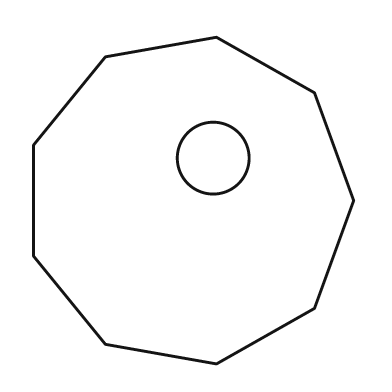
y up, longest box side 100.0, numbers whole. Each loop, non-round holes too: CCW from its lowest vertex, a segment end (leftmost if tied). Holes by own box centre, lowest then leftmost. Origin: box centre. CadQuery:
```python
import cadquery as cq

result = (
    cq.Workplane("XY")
    .moveTo(7.0, -50.0)
    .lineTo(37.0, -33.0)
    .lineTo(49.0, 0.0)
    .lineTo(37.0, 33.0)
    .lineTo(7.0, 50.0)
    .lineTo(-27.0, 44.0)
    .lineTo(-49.0, 17.0)
    .lineTo(-49.0, -17.0)
    .lineTo(-27.0, -44.0)
    .close()
    .moveTo(6.0, 13.0)
    .circle(11.0)
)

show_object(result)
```